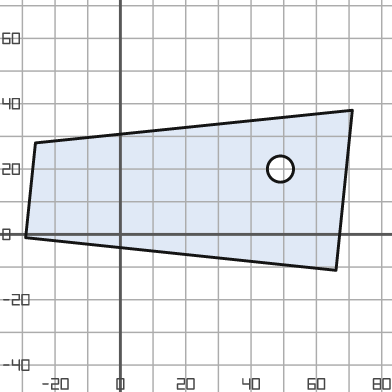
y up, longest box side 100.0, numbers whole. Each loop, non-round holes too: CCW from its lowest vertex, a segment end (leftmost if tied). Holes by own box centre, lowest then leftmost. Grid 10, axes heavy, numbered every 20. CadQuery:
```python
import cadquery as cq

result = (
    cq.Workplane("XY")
    .moveTo(66.0, -11.0)
    .lineTo(71.0, 38.0)
    .lineTo(-26.0, 28.0)
    .lineTo(-29.0, -1.0)
    .close()
    .moveTo(49.0, 20.0)
    .circle(4.0)
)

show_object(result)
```